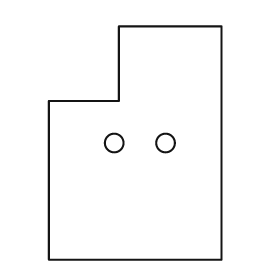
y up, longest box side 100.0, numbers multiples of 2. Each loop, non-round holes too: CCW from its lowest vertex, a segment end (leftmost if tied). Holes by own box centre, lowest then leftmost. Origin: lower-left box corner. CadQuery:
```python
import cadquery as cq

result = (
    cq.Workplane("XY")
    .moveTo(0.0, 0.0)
    .lineTo(74.0, 0.0)
    .lineTo(74.0, 100.0)
    .lineTo(30.0, 100.0)
    .lineTo(30.0, 68.0)
    .lineTo(0.0, 68.0)
    .close()
    .moveTo(28.0, 50.0)
    .circle(4.0)
    .moveTo(50.0, 50.0)
    .circle(4.0)
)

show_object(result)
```